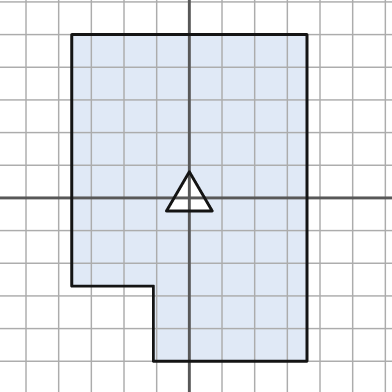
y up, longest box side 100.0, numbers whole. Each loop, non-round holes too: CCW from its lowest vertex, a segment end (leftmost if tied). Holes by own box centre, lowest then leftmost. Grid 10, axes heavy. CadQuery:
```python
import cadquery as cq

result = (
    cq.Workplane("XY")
    .moveTo(-11.0, -50.0)
    .lineTo(36.0, -50.0)
    .lineTo(36.0, 50.0)
    .lineTo(-36.0, 50.0)
    .lineTo(-36.0, -27.0)
    .lineTo(-11.0, -27.0)
    .close()
    .moveTo(-7.0, -4.0)
    .lineTo(7.0, -4.0)
    .lineTo(0.0, 8.0)
    .close()
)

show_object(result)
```